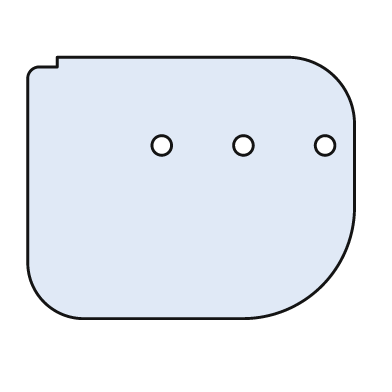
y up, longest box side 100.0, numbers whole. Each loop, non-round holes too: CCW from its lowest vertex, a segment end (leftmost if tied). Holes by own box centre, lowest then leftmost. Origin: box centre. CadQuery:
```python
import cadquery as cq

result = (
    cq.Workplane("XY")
    .moveTo(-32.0, -40.0)
    .lineTo(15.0, -40.0)
    .threePointArc((40.0, -30.0), (50.0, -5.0))
    .lineTo(50.0, 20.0)
    .threePointArc((44.0, 34.0), (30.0, 40.0))
    .lineTo(-41.0, 40.0)
    .lineTo(-41.0, 37.0)
    .lineTo(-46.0, 37.0)
    .threePointArc((-49.0, 36.0), (-50.0, 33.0))
    .lineTo(-50.0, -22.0)
    .threePointArc((-45.0, -35.0), (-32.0, -40.0))
    .close()
    .moveTo(-9.0, 13.0)
    .circle(3.0)
    .moveTo(16.0, 13.0)
    .circle(3.0)
    .moveTo(41.0, 13.0)
    .circle(3.0)
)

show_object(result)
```